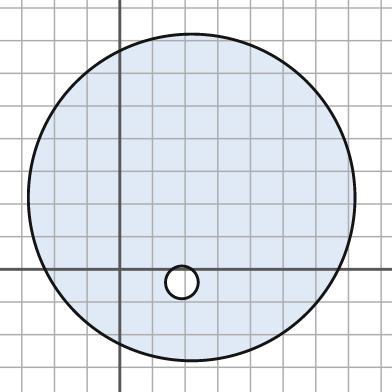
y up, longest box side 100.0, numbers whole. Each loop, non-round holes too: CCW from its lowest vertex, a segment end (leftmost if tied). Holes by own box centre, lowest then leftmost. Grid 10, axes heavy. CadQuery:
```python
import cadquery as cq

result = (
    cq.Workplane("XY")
    .moveTo(22.0, 22.0)
    .circle(50.0)
    .moveTo(19.0, -4.0)
    .circle(5.0)
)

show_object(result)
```